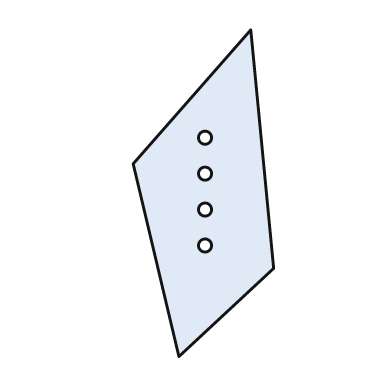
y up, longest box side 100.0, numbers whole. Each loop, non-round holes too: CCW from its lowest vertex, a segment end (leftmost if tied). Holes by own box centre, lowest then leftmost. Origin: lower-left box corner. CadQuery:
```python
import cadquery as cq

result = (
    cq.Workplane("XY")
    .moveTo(14.0, 0.0)
    .lineTo(43.0, 27.0)
    .lineTo(36.0, 100.0)
    .lineTo(0.0, 59.0)
    .close()
    .moveTo(22.0, 34.0)
    .circle(2.0)
    .moveTo(22.0, 45.0)
    .circle(2.0)
    .moveTo(22.0, 56.0)
    .circle(2.0)
    .moveTo(22.0, 67.0)
    .circle(2.0)
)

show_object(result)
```